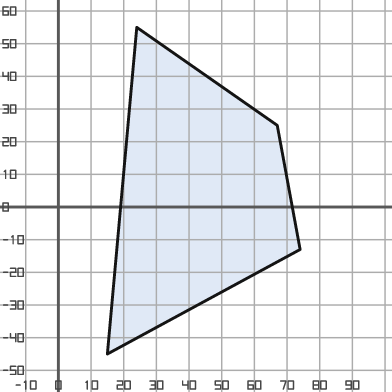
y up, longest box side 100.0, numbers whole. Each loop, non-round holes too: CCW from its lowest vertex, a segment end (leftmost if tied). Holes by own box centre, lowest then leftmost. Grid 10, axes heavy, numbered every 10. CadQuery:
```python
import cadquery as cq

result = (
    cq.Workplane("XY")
    .moveTo(15.0, -45.0)
    .lineTo(74.0, -13.0)
    .lineTo(67.0, 25.0)
    .lineTo(24.0, 55.0)
    .close()
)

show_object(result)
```